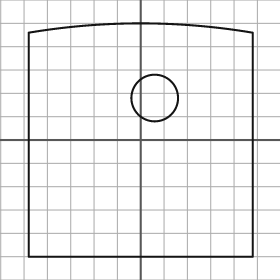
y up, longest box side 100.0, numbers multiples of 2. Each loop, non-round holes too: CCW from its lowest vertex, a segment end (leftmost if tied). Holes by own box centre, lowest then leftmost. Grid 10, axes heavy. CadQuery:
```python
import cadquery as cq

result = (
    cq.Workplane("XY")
    .moveTo(-48.0, -50.0)
    .lineTo(48.0, -50.0)
    .lineTo(48.0, 46.0)
    .threePointArc((0.0, 50.0), (-48.0, 46.0))
    .close()
    .moveTo(6.0, 18.0)
    .circle(10.0)
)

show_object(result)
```